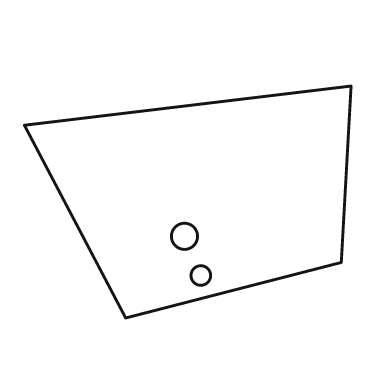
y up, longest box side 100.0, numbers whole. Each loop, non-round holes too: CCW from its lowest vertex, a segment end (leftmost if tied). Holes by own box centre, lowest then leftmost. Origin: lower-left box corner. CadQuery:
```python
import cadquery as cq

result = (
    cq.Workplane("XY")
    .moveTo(31.0, 0.0)
    .lineTo(97.0, 17.0)
    .lineTo(100.0, 71.0)
    .lineTo(0.0, 59.0)
    .close()
    .moveTo(54.0, 13.0)
    .circle(3.0)
    .moveTo(49.0, 25.0)
    .circle(4.0)
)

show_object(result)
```